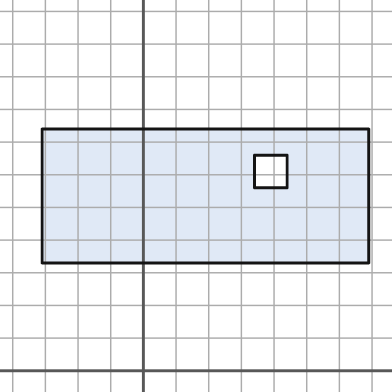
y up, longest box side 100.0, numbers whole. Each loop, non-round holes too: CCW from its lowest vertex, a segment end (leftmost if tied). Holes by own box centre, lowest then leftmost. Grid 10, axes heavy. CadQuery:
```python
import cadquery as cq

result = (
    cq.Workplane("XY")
    .moveTo(-31.0, 33.0)
    .lineTo(69.0, 33.0)
    .lineTo(69.0, 74.0)
    .lineTo(-31.0, 74.0)
    .close()
    .moveTo(34.0, 56.0)
    .lineTo(44.0, 56.0)
    .lineTo(44.0, 66.0)
    .lineTo(34.0, 66.0)
    .close()
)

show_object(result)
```